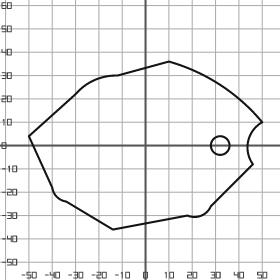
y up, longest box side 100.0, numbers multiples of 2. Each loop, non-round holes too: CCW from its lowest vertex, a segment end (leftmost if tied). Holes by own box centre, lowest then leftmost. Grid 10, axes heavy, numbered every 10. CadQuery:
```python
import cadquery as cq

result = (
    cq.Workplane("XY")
    .moveTo(-14.0, -36.0)
    .lineTo(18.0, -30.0)
    .threePointArc((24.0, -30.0), (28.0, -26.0))
    .lineTo(46.0, -8.0)
    .threePointArc((44.0, 2.0), (50.0, 10.0))
    .threePointArc((32.0, 26.0), (10.0, 36.0))
    .lineTo(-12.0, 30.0)
    .threePointArc((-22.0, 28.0), (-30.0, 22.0))
    .lineTo(-50.0, 4.0)
    .lineTo(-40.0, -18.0)
    .threePointArc((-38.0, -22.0), (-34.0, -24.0))
    .close()
    .moveTo(32.0, 0.0)
    .circle(4.0)
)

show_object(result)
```